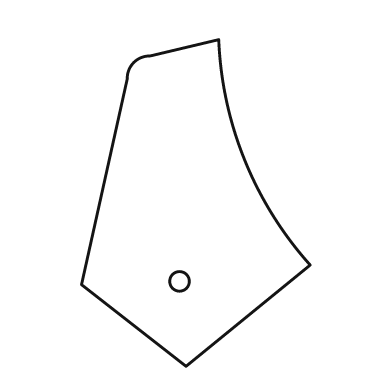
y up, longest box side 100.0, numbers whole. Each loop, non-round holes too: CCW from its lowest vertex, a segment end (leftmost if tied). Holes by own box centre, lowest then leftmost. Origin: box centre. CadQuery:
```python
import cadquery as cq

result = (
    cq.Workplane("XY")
    .moveTo(-3.0, -50.0)
    .lineTo(35.0, -19.0)
    .threePointArc((15.0, 13.0), (7.0, 50.0))
    .lineTo(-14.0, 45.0)
    .threePointArc((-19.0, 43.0), (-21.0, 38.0))
    .lineTo(-35.0, -25.0)
    .close()
    .moveTo(-5.0, -24.0)
    .circle(3.0)
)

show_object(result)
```